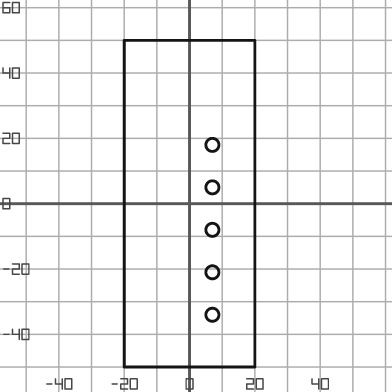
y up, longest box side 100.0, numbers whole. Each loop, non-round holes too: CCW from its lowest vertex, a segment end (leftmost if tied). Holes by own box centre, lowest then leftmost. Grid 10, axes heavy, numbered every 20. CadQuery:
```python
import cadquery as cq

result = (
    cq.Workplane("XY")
    .moveTo(-20.0, -50.0)
    .lineTo(20.0, -50.0)
    .lineTo(20.0, 50.0)
    .lineTo(-20.0, 50.0)
    .close()
    .moveTo(7.0, -34.0)
    .circle(2.0)
    .moveTo(7.0, -21.0)
    .circle(2.0)
    .moveTo(7.0, -8.0)
    .circle(2.0)
    .moveTo(7.0, 5.0)
    .circle(2.0)
    .moveTo(7.0, 18.0)
    .circle(2.0)
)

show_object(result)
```